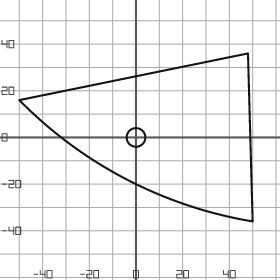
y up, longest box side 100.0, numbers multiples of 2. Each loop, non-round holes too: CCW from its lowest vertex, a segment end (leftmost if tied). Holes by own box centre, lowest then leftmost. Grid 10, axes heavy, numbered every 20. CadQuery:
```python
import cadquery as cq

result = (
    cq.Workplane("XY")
    .moveTo(50.0, -36.0)
    .lineTo(48.0, 36.0)
    .lineTo(-50.0, 16.0)
    .threePointArc((-4.0, -18.0), (50.0, -36.0))
    .close()
    .moveTo(0.0, 0.0)
    .circle(4.0)
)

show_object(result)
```